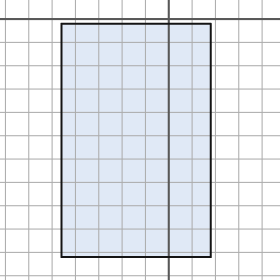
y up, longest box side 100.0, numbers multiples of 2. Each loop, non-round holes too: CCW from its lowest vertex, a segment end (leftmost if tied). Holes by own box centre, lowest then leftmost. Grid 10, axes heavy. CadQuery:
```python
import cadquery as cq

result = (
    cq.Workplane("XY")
    .moveTo(-46.0, -102.0)
    .lineTo(18.0, -102.0)
    .lineTo(18.0, -2.0)
    .lineTo(-46.0, -2.0)
    .close()
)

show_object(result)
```